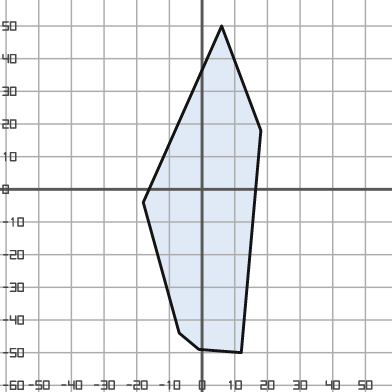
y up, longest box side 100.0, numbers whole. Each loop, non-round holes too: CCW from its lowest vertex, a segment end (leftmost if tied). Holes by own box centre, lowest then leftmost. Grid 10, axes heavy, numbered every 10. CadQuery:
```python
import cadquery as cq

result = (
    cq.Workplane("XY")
    .moveTo(12.0, -50.0)
    .lineTo(18.0, 18.0)
    .lineTo(6.0, 50.0)
    .lineTo(-18.0, -4.0)
    .lineTo(-7.0, -44.0)
    .lineTo(-1.0, -49.0)
    .close()
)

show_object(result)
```